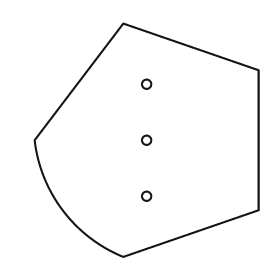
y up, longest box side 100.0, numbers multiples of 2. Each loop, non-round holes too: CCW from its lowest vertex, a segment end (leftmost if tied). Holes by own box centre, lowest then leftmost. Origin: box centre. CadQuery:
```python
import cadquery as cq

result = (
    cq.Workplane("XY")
    .moveTo(-10.0, -50.0)
    .lineTo(48.0, -30.0)
    .lineTo(48.0, 30.0)
    .lineTo(-10.0, 50.0)
    .lineTo(-48.0, 0.0)
    .threePointArc((-36.0, -30.0), (-10.0, -50.0))
    .close()
    .moveTo(0.0, -24.0)
    .circle(2.0)
    .moveTo(0.0, 0.0)
    .circle(2.0)
    .moveTo(0.0, 24.0)
    .circle(2.0)
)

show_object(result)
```